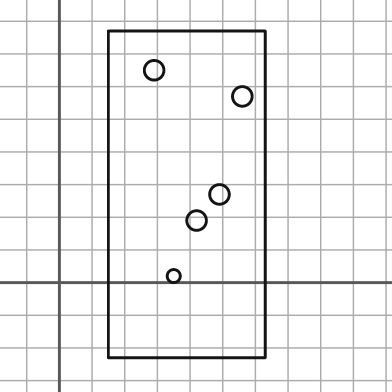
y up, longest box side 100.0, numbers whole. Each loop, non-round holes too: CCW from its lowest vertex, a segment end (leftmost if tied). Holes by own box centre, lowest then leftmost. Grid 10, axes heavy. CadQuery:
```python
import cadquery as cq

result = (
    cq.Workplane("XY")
    .moveTo(15.0, -23.0)
    .lineTo(63.0, -23.0)
    .lineTo(63.0, 77.0)
    .lineTo(15.0, 77.0)
    .close()
    .moveTo(35.0, 2.0)
    .circle(2.0)
    .moveTo(42.0, 19.0)
    .circle(3.0)
    .moveTo(49.0, 27.0)
    .circle(3.0)
    .moveTo(56.0, 57.0)
    .circle(3.0)
    .moveTo(29.0, 65.0)
    .circle(3.0)
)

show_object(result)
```